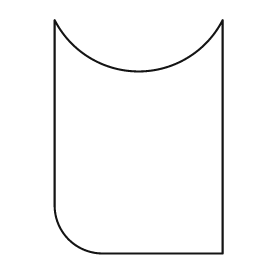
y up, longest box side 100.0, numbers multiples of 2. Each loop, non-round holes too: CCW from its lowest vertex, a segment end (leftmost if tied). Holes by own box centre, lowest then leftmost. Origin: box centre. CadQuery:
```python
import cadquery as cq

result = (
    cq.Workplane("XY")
    .moveTo(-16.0, -50.0)
    .lineTo(36.0, -50.0)
    .lineTo(36.0, 50.0)
    .threePointArc((0.0, 28.0), (-36.0, 50.0))
    .lineTo(-36.0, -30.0)
    .threePointArc((-30.0, -44.0), (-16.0, -50.0))
    .close()
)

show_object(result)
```